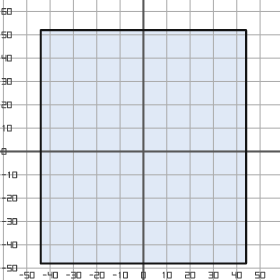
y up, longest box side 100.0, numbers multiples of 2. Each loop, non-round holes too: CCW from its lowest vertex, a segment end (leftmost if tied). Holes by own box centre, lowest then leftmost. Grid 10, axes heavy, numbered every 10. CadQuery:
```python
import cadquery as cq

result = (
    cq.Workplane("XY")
    .moveTo(-44.0, -48.0)
    .lineTo(44.0, -48.0)
    .lineTo(44.0, 52.0)
    .lineTo(-44.0, 52.0)
    .close()
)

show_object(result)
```